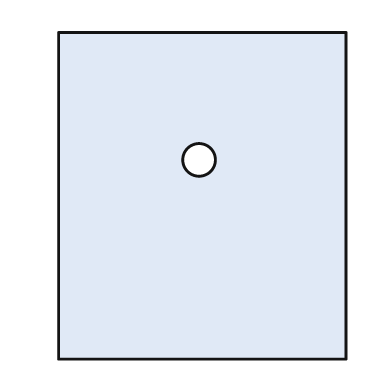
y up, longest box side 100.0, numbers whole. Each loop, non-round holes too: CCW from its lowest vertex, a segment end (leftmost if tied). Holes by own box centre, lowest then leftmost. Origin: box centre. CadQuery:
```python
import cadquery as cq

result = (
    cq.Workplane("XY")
    .moveTo(-44.0, -50.0)
    .lineTo(44.0, -50.0)
    .lineTo(44.0, 50.0)
    .lineTo(-44.0, 50.0)
    .close()
    .moveTo(-1.0, 11.0)
    .circle(5.0)
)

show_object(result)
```